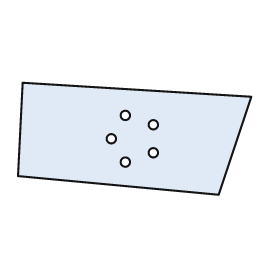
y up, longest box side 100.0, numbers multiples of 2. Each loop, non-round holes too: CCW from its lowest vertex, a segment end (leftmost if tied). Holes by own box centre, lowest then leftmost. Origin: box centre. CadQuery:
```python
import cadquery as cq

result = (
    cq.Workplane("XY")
    .moveTo(36.0, -24.0)
    .lineTo(50.0, 18.0)
    .lineTo(-48.0, 24.0)
    .lineTo(-50.0, -16.0)
    .close()
    .moveTo(-4.0, -10.0)
    .circle(2.0)
    .moveTo(8.0, -6.0)
    .circle(2.0)
    .moveTo(-10.0, 0.0)
    .circle(2.0)
    .moveTo(8.0, 6.0)
    .circle(2.0)
    .moveTo(-4.0, 10.0)
    .circle(2.0)
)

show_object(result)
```